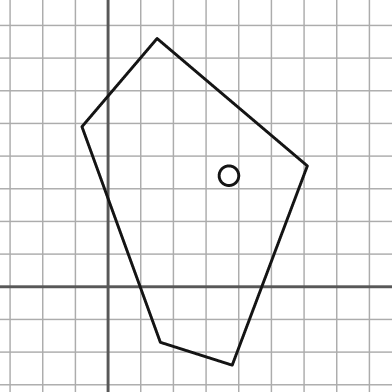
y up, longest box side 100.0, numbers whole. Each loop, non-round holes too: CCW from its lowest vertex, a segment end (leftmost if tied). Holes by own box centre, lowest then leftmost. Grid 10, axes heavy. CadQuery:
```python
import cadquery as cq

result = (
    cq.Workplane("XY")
    .moveTo(38.0, -24.0)
    .lineTo(61.0, 37.0)
    .lineTo(15.0, 76.0)
    .lineTo(-8.0, 49.0)
    .lineTo(16.0, -17.0)
    .close()
    .moveTo(37.0, 34.0)
    .circle(3.0)
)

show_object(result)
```